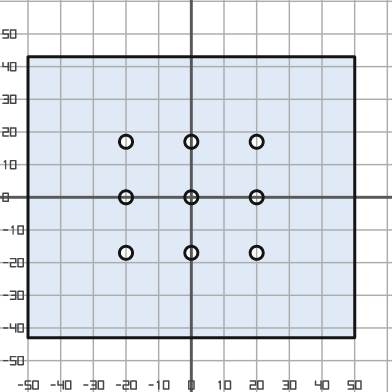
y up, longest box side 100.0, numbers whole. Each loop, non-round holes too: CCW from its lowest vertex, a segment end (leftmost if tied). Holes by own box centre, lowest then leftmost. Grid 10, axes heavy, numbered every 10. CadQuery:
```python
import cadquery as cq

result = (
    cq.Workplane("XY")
    .moveTo(-50.0, -43.0)
    .lineTo(50.0, -43.0)
    .lineTo(50.0, 43.0)
    .lineTo(-50.0, 43.0)
    .close()
    .moveTo(-20.0, -17.0)
    .circle(2.0)
    .moveTo(0.0, -17.0)
    .circle(2.0)
    .moveTo(20.0, -17.0)
    .circle(2.0)
    .moveTo(-20.0, 0.0)
    .circle(2.0)
    .moveTo(0.0, 0.0)
    .circle(2.0)
    .moveTo(20.0, 0.0)
    .circle(2.0)
    .moveTo(-20.0, 17.0)
    .circle(2.0)
    .moveTo(0.0, 17.0)
    .circle(2.0)
    .moveTo(20.0, 17.0)
    .circle(2.0)
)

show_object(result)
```